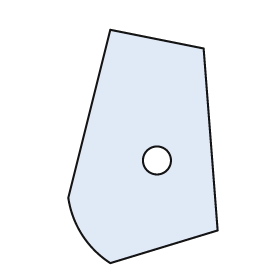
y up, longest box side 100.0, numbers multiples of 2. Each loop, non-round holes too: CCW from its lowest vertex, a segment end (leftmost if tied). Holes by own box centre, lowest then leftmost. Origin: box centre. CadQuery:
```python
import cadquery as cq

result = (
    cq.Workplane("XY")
    .moveTo(-14.0, -50.0)
    .lineTo(32.0, -36.0)
    .lineTo(26.0, 42.0)
    .lineTo(-14.0, 50.0)
    .lineTo(-32.0, -22.0)
    .threePointArc((-26.0, -38.0), (-14.0, -50.0))
    .close()
    .moveTo(6.0, -6.0)
    .circle(6.0)
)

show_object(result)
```